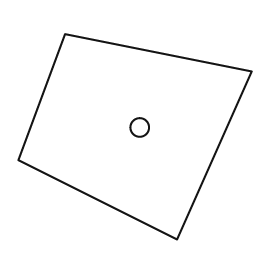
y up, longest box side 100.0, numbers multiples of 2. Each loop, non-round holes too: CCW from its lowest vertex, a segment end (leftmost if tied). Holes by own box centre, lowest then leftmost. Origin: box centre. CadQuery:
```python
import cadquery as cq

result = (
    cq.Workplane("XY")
    .moveTo(18.0, -44.0)
    .lineTo(50.0, 28.0)
    .lineTo(-30.0, 44.0)
    .lineTo(-50.0, -10.0)
    .close()
    .moveTo(2.0, 4.0)
    .circle(4.0)
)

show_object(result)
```